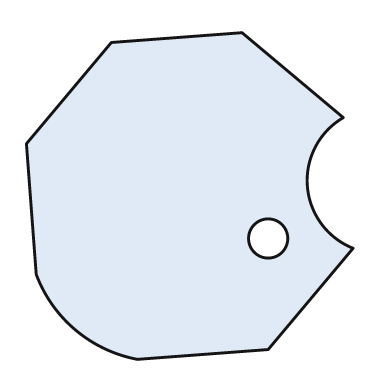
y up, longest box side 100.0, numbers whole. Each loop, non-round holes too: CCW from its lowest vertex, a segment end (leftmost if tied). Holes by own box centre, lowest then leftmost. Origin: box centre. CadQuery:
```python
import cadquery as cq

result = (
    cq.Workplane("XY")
    .moveTo(-16.0, -50.0)
    .lineTo(24.0, -47.0)
    .lineTo(50.0, -16.0)
    .threePointArc((36.0, 3.0), (47.0, 24.0))
    .lineTo(16.0, 50.0)
    .lineTo(-24.0, 47.0)
    .lineTo(-50.0, 16.0)
    .lineTo(-47.0, -24.0)
    .threePointArc((-35.0, -41.0), (-16.0, -50.0))
    .close()
    .moveTo(24.0, -13.0)
    .circle(6.0)
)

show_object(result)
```